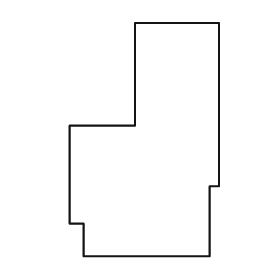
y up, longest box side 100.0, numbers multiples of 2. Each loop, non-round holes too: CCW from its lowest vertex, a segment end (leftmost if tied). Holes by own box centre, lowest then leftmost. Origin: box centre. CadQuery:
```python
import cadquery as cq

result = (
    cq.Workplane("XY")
    .moveTo(-26.0, -50.0)
    .lineTo(28.0, -50.0)
    .lineTo(28.0, -20.0)
    .lineTo(32.0, -20.0)
    .lineTo(32.0, 50.0)
    .lineTo(-4.0, 50.0)
    .lineTo(-4.0, 6.0)
    .lineTo(-32.0, 6.0)
    .lineTo(-32.0, -36.0)
    .lineTo(-26.0, -36.0)
    .close()
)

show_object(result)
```